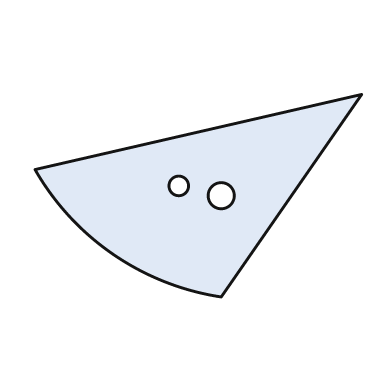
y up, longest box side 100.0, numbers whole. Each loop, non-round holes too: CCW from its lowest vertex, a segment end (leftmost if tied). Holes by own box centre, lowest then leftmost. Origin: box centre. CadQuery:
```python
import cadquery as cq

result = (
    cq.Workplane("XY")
    .moveTo(7.0, -31.0)
    .lineTo(50.0, 31.0)
    .lineTo(-50.0, 8.0)
    .threePointArc((-26.0, -18.0), (7.0, -31.0))
    .close()
    .moveTo(7.0, 0.0)
    .circle(4.0)
    .moveTo(-6.0, 3.0)
    .circle(3.0)
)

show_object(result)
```